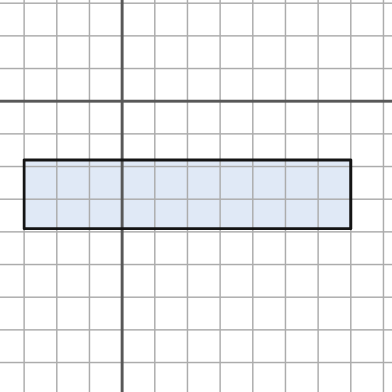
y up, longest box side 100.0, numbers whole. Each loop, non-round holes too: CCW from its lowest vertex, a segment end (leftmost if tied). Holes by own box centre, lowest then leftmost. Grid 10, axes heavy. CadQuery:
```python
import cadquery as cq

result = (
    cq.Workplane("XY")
    .moveTo(-30.0, -39.0)
    .lineTo(70.0, -39.0)
    .lineTo(70.0, -18.0)
    .lineTo(-30.0, -18.0)
    .close()
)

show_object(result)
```